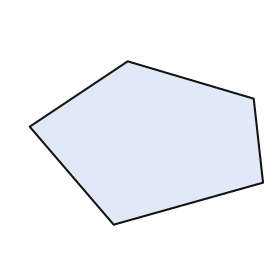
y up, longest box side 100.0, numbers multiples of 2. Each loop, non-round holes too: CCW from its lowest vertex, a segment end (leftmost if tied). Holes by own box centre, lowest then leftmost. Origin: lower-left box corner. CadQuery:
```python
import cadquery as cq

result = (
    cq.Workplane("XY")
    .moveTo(36.0, 0.0)
    .lineTo(100.0, 18.0)
    .lineTo(96.0, 54.0)
    .lineTo(42.0, 70.0)
    .lineTo(0.0, 42.0)
    .close()
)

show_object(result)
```